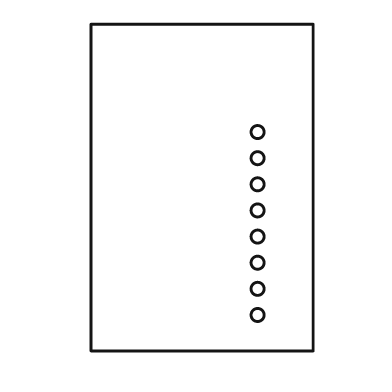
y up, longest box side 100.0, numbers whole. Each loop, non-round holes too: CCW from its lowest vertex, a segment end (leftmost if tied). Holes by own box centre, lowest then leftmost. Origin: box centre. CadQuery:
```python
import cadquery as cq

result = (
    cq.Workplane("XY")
    .moveTo(-34.0, -50.0)
    .lineTo(34.0, -50.0)
    .lineTo(34.0, 50.0)
    .lineTo(-34.0, 50.0)
    .close()
    .moveTo(17.0, -39.0)
    .circle(2.0)
    .moveTo(17.0, -31.0)
    .circle(2.0)
    .moveTo(17.0, -23.0)
    .circle(2.0)
    .moveTo(17.0, -15.0)
    .circle(2.0)
    .moveTo(17.0, -7.0)
    .circle(2.0)
    .moveTo(17.0, 1.0)
    .circle(2.0)
    .moveTo(17.0, 9.0)
    .circle(2.0)
    .moveTo(17.0, 17.0)
    .circle(2.0)
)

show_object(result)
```